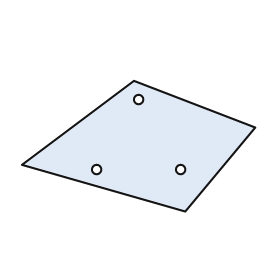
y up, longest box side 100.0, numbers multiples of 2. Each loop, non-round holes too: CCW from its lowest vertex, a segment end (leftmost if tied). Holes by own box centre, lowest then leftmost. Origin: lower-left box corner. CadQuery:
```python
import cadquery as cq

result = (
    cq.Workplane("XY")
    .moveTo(70.0, 0.0)
    .lineTo(100.0, 36.0)
    .lineTo(48.0, 56.0)
    .lineTo(0.0, 20.0)
    .close()
    .moveTo(32.0, 18.0)
    .circle(2.0)
    .moveTo(68.0, 18.0)
    .circle(2.0)
    .moveTo(50.0, 48.0)
    .circle(2.0)
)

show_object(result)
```